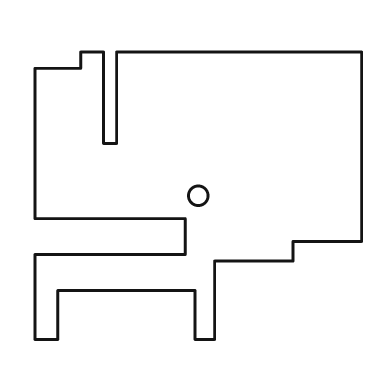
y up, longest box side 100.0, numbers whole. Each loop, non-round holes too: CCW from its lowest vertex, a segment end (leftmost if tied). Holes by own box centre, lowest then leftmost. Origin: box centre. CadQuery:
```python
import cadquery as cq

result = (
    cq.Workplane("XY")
    .moveTo(-50.0, -44.0)
    .lineTo(-43.0, -44.0)
    .lineTo(-43.0, -29.0)
    .lineTo(-1.0, -29.0)
    .lineTo(-1.0, -44.0)
    .lineTo(5.0, -44.0)
    .lineTo(5.0, -20.0)
    .lineTo(29.0, -20.0)
    .lineTo(29.0, -14.0)
    .lineTo(50.0, -14.0)
    .lineTo(50.0, 44.0)
    .lineTo(-25.0, 44.0)
    .lineTo(-25.0, 16.0)
    .lineTo(-29.0, 16.0)
    .lineTo(-29.0, 44.0)
    .lineTo(-36.0, 44.0)
    .lineTo(-36.0, 39.0)
    .lineTo(-50.0, 39.0)
    .lineTo(-50.0, -7.0)
    .lineTo(-4.0, -7.0)
    .lineTo(-4.0, -18.0)
    .lineTo(-50.0, -18.0)
    .close()
    .moveTo(0.0, 0.0)
    .circle(3.0)
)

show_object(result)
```